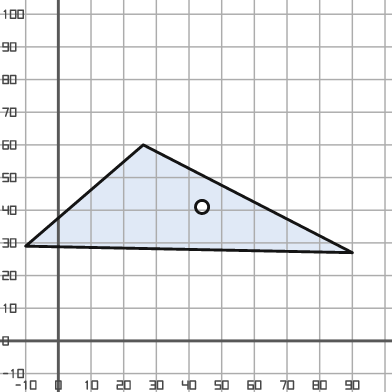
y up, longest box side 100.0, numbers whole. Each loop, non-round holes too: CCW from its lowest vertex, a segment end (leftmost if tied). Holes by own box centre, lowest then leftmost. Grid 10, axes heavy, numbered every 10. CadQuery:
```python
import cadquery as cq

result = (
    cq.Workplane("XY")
    .moveTo(90.0, 27.0)
    .lineTo(26.0, 60.0)
    .lineTo(-10.0, 29.0)
    .close()
    .moveTo(44.0, 41.0)
    .circle(2.0)
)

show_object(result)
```